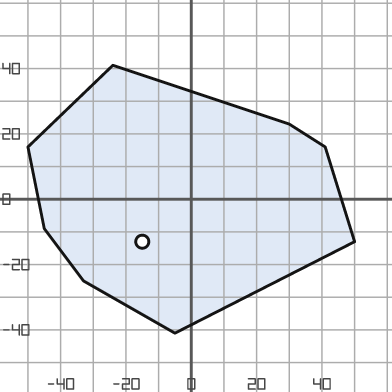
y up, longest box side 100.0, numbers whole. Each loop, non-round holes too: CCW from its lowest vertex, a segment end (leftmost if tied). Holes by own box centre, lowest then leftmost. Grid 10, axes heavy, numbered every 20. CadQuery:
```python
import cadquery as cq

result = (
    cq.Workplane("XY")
    .moveTo(-5.0, -41.0)
    .lineTo(50.0, -13.0)
    .lineTo(41.0, 16.0)
    .lineTo(30.0, 23.0)
    .lineTo(-24.0, 41.0)
    .lineTo(-50.0, 16.0)
    .lineTo(-45.0, -9.0)
    .lineTo(-33.0, -25.0)
    .close()
    .moveTo(-15.0, -13.0)
    .circle(2.0)
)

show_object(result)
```